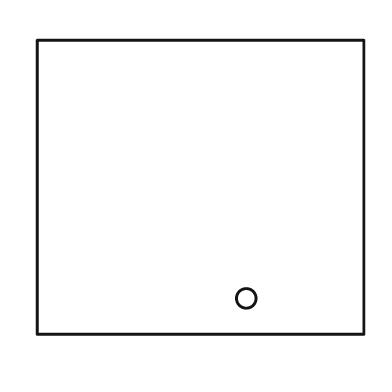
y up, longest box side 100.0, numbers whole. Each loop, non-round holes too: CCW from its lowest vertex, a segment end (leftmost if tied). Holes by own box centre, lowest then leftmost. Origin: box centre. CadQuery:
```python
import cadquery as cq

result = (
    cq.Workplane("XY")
    .moveTo(-50.0, -45.0)
    .lineTo(50.0, -45.0)
    .lineTo(50.0, 45.0)
    .lineTo(-50.0, 45.0)
    .close()
    .moveTo(14.0, -34.0)
    .circle(3.0)
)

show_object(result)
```